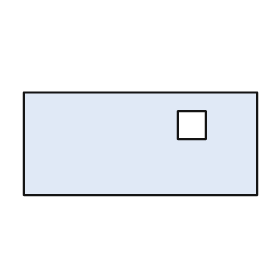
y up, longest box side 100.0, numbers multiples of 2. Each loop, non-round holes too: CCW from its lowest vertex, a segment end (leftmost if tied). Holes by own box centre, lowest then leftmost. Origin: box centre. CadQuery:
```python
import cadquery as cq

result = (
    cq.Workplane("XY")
    .moveTo(-50.0, -22.0)
    .lineTo(50.0, -22.0)
    .lineTo(50.0, 22.0)
    .lineTo(-50.0, 22.0)
    .close()
    .moveTo(16.0, 2.0)
    .lineTo(28.0, 2.0)
    .lineTo(28.0, 14.0)
    .lineTo(16.0, 14.0)
    .close()
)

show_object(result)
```